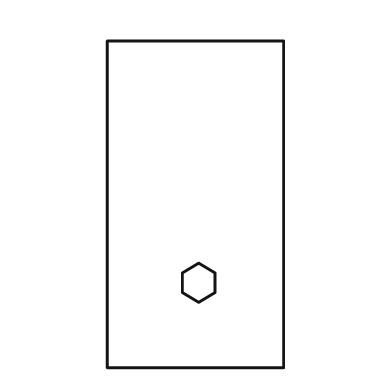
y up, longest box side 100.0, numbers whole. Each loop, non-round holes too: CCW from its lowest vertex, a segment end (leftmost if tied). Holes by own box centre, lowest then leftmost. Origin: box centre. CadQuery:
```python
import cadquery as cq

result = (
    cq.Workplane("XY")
    .moveTo(-27.0, -50.0)
    .lineTo(27.0, -50.0)
    .lineTo(27.0, 50.0)
    .lineTo(-27.0, 50.0)
    .close()
    .moveTo(1.0, -30.0)
    .lineTo(6.0, -27.0)
    .lineTo(6.0, -21.0)
    .lineTo(1.0, -18.0)
    .lineTo(-4.0, -21.0)
    .lineTo(-4.0, -27.0)
    .close()
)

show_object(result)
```